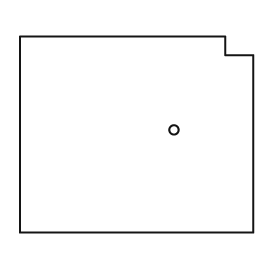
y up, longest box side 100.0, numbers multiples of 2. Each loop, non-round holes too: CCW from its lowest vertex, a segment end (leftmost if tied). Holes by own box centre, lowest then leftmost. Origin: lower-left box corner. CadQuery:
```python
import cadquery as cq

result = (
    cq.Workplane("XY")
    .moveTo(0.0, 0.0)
    .lineTo(100.0, 0.0)
    .lineTo(100.0, 76.0)
    .lineTo(88.0, 76.0)
    .lineTo(88.0, 84.0)
    .lineTo(0.0, 84.0)
    .close()
    .moveTo(66.0, 44.0)
    .circle(2.0)
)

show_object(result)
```